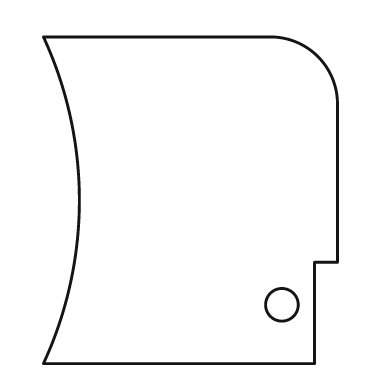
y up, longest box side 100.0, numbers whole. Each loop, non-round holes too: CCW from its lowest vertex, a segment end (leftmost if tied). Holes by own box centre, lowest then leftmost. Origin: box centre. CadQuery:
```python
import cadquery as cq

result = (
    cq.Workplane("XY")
    .moveTo(-45.0, -50.0)
    .lineTo(38.0, -50.0)
    .lineTo(38.0, -19.0)
    .lineTo(45.0, -19.0)
    .lineTo(45.0, 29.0)
    .threePointArc((39.0, 44.0), (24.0, 50.0))
    .lineTo(-45.0, 50.0)
    .threePointArc((-34.0, 0.0), (-45.0, -50.0))
    .close()
    .moveTo(28.0, -32.0)
    .circle(5.0)
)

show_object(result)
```